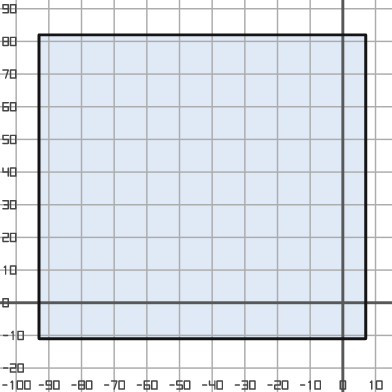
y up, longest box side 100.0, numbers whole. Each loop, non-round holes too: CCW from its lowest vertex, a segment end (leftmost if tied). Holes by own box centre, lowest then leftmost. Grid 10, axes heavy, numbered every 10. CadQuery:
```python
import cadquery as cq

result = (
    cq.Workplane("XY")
    .moveTo(-93.0, -11.0)
    .lineTo(7.0, -11.0)
    .lineTo(7.0, 82.0)
    .lineTo(-93.0, 82.0)
    .close()
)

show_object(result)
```